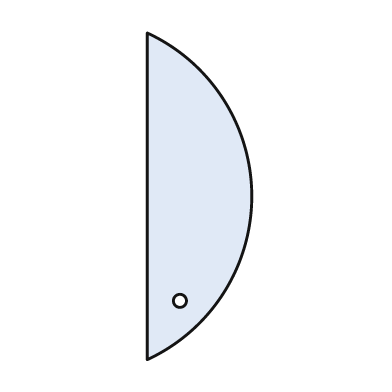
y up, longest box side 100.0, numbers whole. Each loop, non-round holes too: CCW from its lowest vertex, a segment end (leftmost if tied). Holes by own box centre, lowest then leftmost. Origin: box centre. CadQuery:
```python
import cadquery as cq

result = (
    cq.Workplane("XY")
    .moveTo(-16.0, -50.0)
    .threePointArc((16.0, 0.0), (-16.0, 50.0))
    .close()
    .moveTo(-6.0, -32.0)
    .circle(2.0)
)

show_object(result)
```